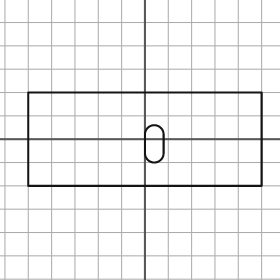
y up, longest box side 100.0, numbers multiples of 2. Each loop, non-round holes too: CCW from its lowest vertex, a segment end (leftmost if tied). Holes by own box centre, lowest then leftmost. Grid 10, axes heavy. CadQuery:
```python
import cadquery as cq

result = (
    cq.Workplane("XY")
    .moveTo(-50.0, -20.0)
    .lineTo(50.0, -20.0)
    .lineTo(50.0, 20.0)
    .lineTo(-50.0, 20.0)
    .close()
    .moveTo(0.0, -6.0)
    .threePointArc((4.0, -10.0), (8.0, -6.0))
    .lineTo(8.0, 2.0)
    .threePointArc((4.0, 6.0), (0.0, 2.0))
    .close()
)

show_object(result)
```